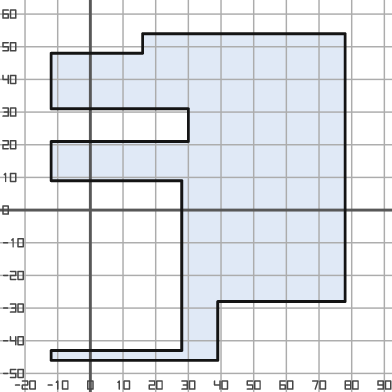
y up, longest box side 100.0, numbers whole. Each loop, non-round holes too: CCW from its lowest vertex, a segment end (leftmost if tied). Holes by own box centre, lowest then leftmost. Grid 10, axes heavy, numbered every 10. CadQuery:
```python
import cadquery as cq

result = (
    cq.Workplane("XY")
    .moveTo(-12.0, -46.0)
    .lineTo(39.0, -46.0)
    .lineTo(39.0, -28.0)
    .lineTo(78.0, -28.0)
    .lineTo(78.0, 54.0)
    .lineTo(16.0, 54.0)
    .lineTo(16.0, 48.0)
    .lineTo(-12.0, 48.0)
    .lineTo(-12.0, 31.0)
    .lineTo(30.0, 31.0)
    .lineTo(30.0, 21.0)
    .lineTo(-12.0, 21.0)
    .lineTo(-12.0, 9.0)
    .lineTo(28.0, 9.0)
    .lineTo(28.0, -43.0)
    .lineTo(-12.0, -43.0)
    .close()
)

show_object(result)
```